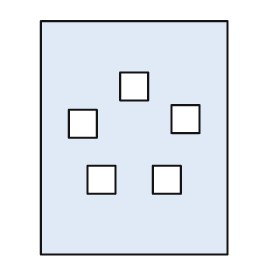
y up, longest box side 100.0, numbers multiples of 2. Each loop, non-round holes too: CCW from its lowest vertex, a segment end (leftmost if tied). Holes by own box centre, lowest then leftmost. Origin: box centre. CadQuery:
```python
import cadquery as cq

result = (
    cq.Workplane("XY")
    .moveTo(-40.0, -50.0)
    .lineTo(40.0, -50.0)
    .lineTo(40.0, 50.0)
    .lineTo(-40.0, 50.0)
    .close()
    .moveTo(-20.0, -24.0)
    .lineTo(-8.0, -24.0)
    .lineTo(-8.0, -12.0)
    .lineTo(-20.0, -12.0)
    .close()
    .moveTo(8.0, -24.0)
    .lineTo(20.0, -24.0)
    .lineTo(20.0, -12.0)
    .lineTo(8.0, -12.0)
    .close()
    .moveTo(-28.0, 0.0)
    .lineTo(-16.0, 0.0)
    .lineTo(-16.0, 12.0)
    .lineTo(-28.0, 12.0)
    .close()
    .moveTo(16.0, 2.0)
    .lineTo(28.0, 2.0)
    .lineTo(28.0, 14.0)
    .lineTo(16.0, 14.0)
    .close()
    .moveTo(-6.0, 16.0)
    .lineTo(6.0, 16.0)
    .lineTo(6.0, 28.0)
    .lineTo(-6.0, 28.0)
    .close()
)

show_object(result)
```